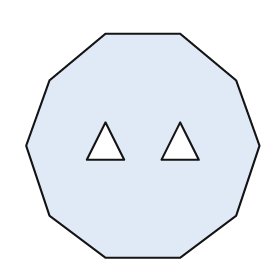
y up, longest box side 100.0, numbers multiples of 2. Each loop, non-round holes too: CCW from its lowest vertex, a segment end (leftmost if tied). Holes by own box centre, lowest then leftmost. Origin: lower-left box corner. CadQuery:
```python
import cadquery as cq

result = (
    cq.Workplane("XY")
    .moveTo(34.0, 0.0)
    .lineTo(66.0, 0.0)
    .lineTo(90.0, 18.0)
    .lineTo(100.0, 48.0)
    .lineTo(90.0, 76.0)
    .lineTo(66.0, 96.0)
    .lineTo(34.0, 96.0)
    .lineTo(10.0, 76.0)
    .lineTo(0.0, 48.0)
    .lineTo(10.0, 18.0)
    .close()
    .moveTo(26.0, 42.0)
    .lineTo(42.0, 42.0)
    .lineTo(34.0, 58.0)
    .close()
    .moveTo(58.0, 42.0)
    .lineTo(74.0, 42.0)
    .lineTo(66.0, 58.0)
    .close()
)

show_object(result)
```